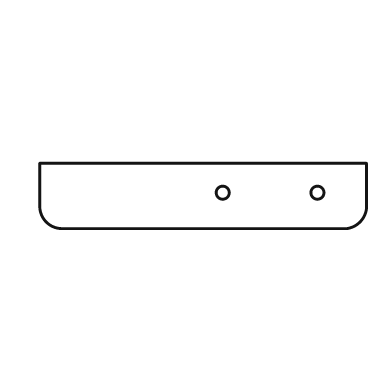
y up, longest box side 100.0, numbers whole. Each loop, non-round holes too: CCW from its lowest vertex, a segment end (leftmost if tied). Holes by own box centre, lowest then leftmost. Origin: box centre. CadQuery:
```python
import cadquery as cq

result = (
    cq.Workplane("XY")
    .moveTo(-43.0, -10.0)
    .lineTo(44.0, -10.0)
    .threePointArc((48.0, -8.0), (50.0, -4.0))
    .lineTo(50.0, 10.0)
    .lineTo(-50.0, 10.0)
    .lineTo(-50.0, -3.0)
    .threePointArc((-48.0, -8.0), (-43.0, -10.0))
    .close()
    .moveTo(6.0, 1.0)
    .circle(2.0)
    .moveTo(35.0, 1.0)
    .circle(2.0)
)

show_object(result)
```